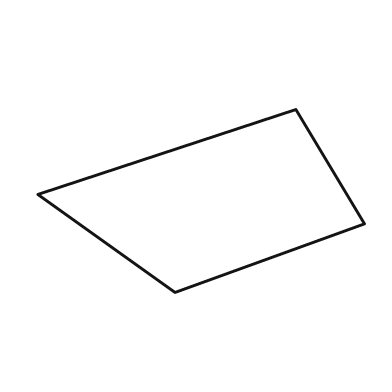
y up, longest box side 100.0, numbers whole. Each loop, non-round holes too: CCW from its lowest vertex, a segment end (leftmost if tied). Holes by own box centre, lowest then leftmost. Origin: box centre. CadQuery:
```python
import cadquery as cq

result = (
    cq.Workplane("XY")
    .moveTo(-8.0, -28.0)
    .lineTo(50.0, -7.0)
    .lineTo(29.0, 28.0)
    .lineTo(-50.0, 2.0)
    .close()
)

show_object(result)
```